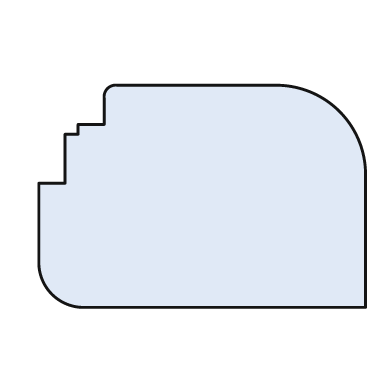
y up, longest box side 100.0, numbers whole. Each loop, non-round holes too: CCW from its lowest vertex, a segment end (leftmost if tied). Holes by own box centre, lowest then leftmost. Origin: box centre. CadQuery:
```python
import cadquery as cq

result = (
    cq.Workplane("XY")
    .moveTo(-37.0, -34.0)
    .lineTo(50.0, -34.0)
    .lineTo(50.0, 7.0)
    .threePointArc((42.0, 26.0), (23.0, 34.0))
    .lineTo(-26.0, 34.0)
    .threePointArc((-29.0, 33.0), (-30.0, 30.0))
    .lineTo(-30.0, 22.0)
    .lineTo(-38.0, 22.0)
    .lineTo(-38.0, 19.0)
    .lineTo(-42.0, 19.0)
    .lineTo(-42.0, 4.0)
    .lineTo(-50.0, 4.0)
    .lineTo(-50.0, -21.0)
    .threePointArc((-46.0, -30.0), (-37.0, -34.0))
    .close()
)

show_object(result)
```